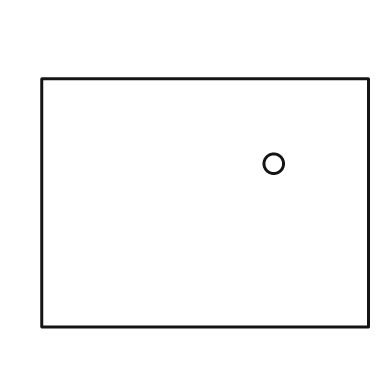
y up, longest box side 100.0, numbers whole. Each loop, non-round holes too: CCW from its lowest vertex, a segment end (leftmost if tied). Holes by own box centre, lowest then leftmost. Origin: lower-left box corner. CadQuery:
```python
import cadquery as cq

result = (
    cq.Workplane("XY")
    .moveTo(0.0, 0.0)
    .lineTo(100.0, 0.0)
    .lineTo(100.0, 76.0)
    .lineTo(0.0, 76.0)
    .close()
    .moveTo(71.0, 50.0)
    .circle(3.0)
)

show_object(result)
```